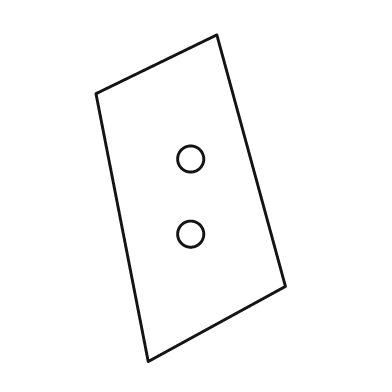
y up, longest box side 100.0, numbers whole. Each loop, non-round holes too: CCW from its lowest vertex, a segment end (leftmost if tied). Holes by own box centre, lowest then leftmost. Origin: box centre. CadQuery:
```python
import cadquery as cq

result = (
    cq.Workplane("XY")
    .moveTo(-13.0, -50.0)
    .lineTo(29.0, -27.0)
    .lineTo(8.0, 50.0)
    .lineTo(-29.0, 32.0)
    .close()
    .moveTo(0.0, -11.0)
    .circle(4.0)
    .moveTo(0.0, 12.0)
    .circle(4.0)
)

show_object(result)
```